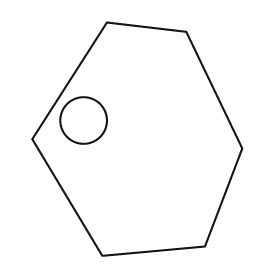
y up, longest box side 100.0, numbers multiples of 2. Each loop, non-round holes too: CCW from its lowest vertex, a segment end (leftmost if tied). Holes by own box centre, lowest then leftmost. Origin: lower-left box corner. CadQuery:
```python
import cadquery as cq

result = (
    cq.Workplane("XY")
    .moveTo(30.0, 0.0)
    .lineTo(74.0, 4.0)
    .lineTo(90.0, 46.0)
    .lineTo(66.0, 96.0)
    .lineTo(32.0, 100.0)
    .lineTo(0.0, 50.0)
    .close()
    .moveTo(22.0, 58.0)
    .circle(10.0)
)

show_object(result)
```